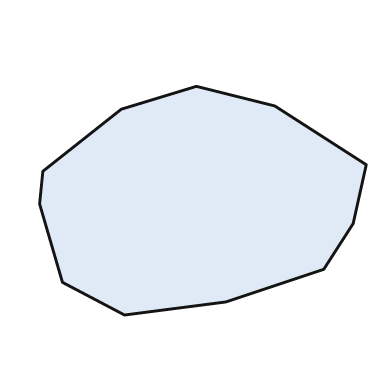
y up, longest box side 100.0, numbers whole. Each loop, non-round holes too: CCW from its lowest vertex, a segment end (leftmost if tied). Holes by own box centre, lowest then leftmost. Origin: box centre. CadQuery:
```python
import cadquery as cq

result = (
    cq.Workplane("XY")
    .moveTo(-24.0, -35.0)
    .lineTo(7.0, -31.0)
    .lineTo(37.0, -21.0)
    .lineTo(46.0, -7.0)
    .lineTo(50.0, 11.0)
    .lineTo(22.0, 29.0)
    .lineTo(-2.0, 35.0)
    .lineTo(-25.0, 28.0)
    .lineTo(-49.0, 9.0)
    .lineTo(-50.0, -1.0)
    .lineTo(-43.0, -25.0)
    .close()
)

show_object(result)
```